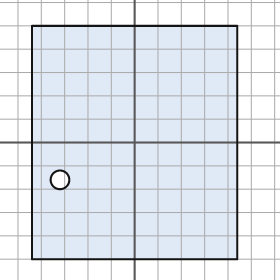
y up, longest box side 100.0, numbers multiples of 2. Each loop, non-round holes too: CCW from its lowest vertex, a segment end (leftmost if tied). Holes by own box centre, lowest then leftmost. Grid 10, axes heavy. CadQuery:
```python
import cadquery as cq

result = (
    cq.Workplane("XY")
    .moveTo(-44.0, -50.0)
    .lineTo(44.0, -50.0)
    .lineTo(44.0, 50.0)
    .lineTo(-44.0, 50.0)
    .close()
    .moveTo(-32.0, -16.0)
    .circle(4.0)
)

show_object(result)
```